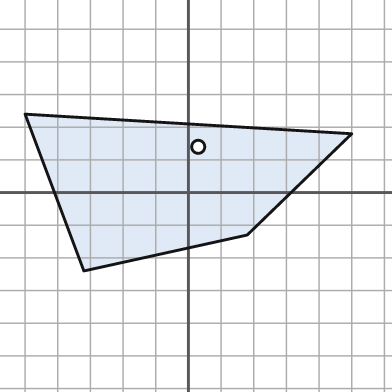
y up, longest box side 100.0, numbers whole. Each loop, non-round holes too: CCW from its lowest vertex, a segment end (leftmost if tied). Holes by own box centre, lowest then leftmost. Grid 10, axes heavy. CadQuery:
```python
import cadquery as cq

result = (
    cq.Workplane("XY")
    .moveTo(-32.0, -24.0)
    .lineTo(18.0, -13.0)
    .lineTo(50.0, 18.0)
    .lineTo(-50.0, 24.0)
    .close()
    .moveTo(3.0, 14.0)
    .circle(2.0)
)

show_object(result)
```